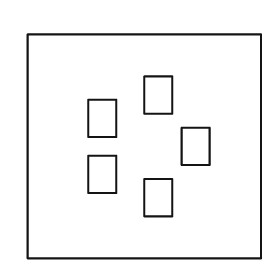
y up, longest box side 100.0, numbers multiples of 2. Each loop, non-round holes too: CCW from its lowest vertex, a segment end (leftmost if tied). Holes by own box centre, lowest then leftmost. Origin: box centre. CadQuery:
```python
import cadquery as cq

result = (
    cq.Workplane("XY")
    .moveTo(-50.0, -48.0)
    .lineTo(50.0, -48.0)
    .lineTo(50.0, 48.0)
    .lineTo(-50.0, 48.0)
    .close()
    .moveTo(0.0, -30.0)
    .lineTo(12.0, -30.0)
    .lineTo(12.0, -14.0)
    .lineTo(0.0, -14.0)
    .close()
    .moveTo(-24.0, -20.0)
    .lineTo(-12.0, -20.0)
    .lineTo(-12.0, -4.0)
    .lineTo(-24.0, -4.0)
    .close()
    .moveTo(16.0, -8.0)
    .lineTo(28.0, -8.0)
    .lineTo(28.0, 8.0)
    .lineTo(16.0, 8.0)
    .close()
    .moveTo(-24.0, 4.0)
    .lineTo(-12.0, 4.0)
    .lineTo(-12.0, 20.0)
    .lineTo(-24.0, 20.0)
    .close()
    .moveTo(0.0, 14.0)
    .lineTo(12.0, 14.0)
    .lineTo(12.0, 30.0)
    .lineTo(0.0, 30.0)
    .close()
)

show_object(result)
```